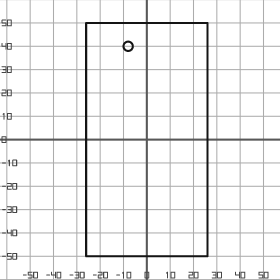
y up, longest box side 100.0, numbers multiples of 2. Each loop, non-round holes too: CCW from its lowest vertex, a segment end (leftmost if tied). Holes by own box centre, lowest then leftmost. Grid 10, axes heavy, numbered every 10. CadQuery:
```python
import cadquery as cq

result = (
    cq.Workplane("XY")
    .moveTo(-26.0, -50.0)
    .lineTo(26.0, -50.0)
    .lineTo(26.0, 50.0)
    .lineTo(-26.0, 50.0)
    .close()
    .moveTo(-8.0, 40.0)
    .circle(2.0)
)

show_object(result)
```